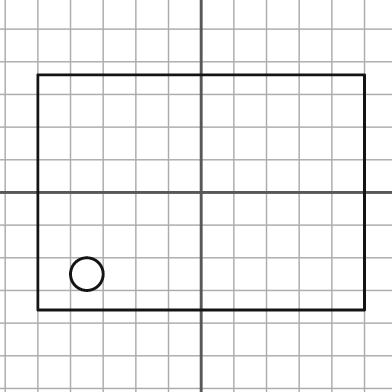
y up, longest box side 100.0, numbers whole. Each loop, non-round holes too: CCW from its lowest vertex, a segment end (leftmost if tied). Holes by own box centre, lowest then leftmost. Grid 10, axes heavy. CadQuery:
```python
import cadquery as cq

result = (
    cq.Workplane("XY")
    .moveTo(-50.0, -36.0)
    .lineTo(50.0, -36.0)
    .lineTo(50.0, 36.0)
    .lineTo(-50.0, 36.0)
    .close()
    .moveTo(-35.0, -25.0)
    .circle(5.0)
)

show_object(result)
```